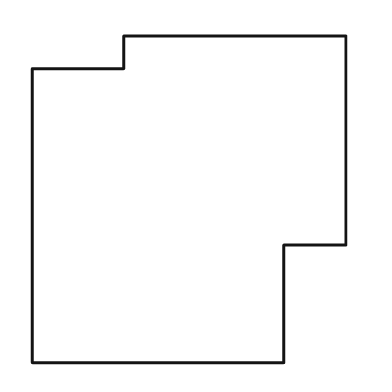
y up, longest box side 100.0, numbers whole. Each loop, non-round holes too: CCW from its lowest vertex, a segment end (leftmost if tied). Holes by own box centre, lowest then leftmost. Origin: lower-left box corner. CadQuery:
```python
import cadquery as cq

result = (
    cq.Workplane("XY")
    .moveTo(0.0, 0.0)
    .lineTo(77.0, 0.0)
    .lineTo(77.0, 36.0)
    .lineTo(96.0, 36.0)
    .lineTo(96.0, 100.0)
    .lineTo(28.0, 100.0)
    .lineTo(28.0, 90.0)
    .lineTo(0.0, 90.0)
    .close()
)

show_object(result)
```